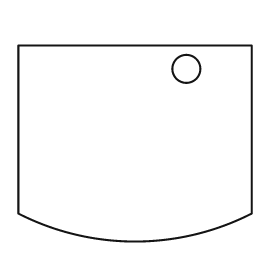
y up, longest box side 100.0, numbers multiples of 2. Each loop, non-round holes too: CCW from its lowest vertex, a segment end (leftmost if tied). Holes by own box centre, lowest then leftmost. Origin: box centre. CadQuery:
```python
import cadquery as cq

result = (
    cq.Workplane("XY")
    .moveTo(-50.0, -30.0)
    .threePointArc((0.0, -42.0), (50.0, -30.0))
    .lineTo(50.0, 42.0)
    .lineTo(-50.0, 42.0)
    .close()
    .moveTo(22.0, 32.0)
    .circle(6.0)
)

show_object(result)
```